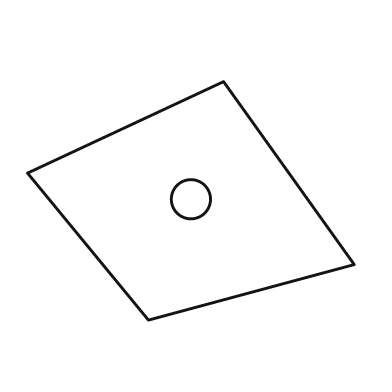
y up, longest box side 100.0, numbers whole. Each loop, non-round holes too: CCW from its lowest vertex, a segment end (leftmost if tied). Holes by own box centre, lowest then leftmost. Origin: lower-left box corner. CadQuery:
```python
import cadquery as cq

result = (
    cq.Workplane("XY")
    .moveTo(37.0, 0.0)
    .lineTo(100.0, 17.0)
    .lineTo(60.0, 73.0)
    .lineTo(0.0, 45.0)
    .close()
    .moveTo(50.0, 37.0)
    .circle(6.0)
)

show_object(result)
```